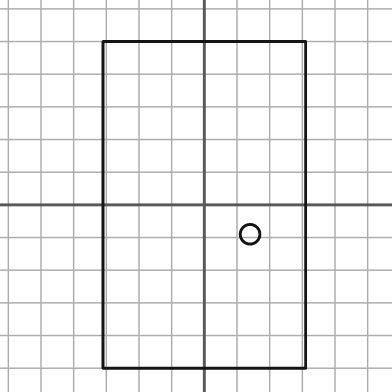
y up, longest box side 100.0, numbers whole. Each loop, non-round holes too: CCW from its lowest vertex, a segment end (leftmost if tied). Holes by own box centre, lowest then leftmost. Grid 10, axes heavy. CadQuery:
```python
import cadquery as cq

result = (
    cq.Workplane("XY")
    .moveTo(-31.0, -50.0)
    .lineTo(31.0, -50.0)
    .lineTo(31.0, 50.0)
    .lineTo(-31.0, 50.0)
    .close()
    .moveTo(14.0, -9.0)
    .circle(3.0)
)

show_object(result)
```